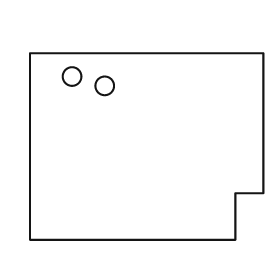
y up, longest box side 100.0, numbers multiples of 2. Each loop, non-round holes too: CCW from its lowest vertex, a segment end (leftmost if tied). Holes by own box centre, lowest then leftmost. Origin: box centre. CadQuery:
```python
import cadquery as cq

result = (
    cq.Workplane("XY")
    .moveTo(-50.0, -40.0)
    .lineTo(38.0, -40.0)
    .lineTo(38.0, -20.0)
    .lineTo(50.0, -20.0)
    .lineTo(50.0, 40.0)
    .lineTo(-50.0, 40.0)
    .close()
    .moveTo(-18.0, 26.0)
    .circle(4.0)
    .moveTo(-32.0, 30.0)
    .circle(4.0)
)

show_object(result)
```